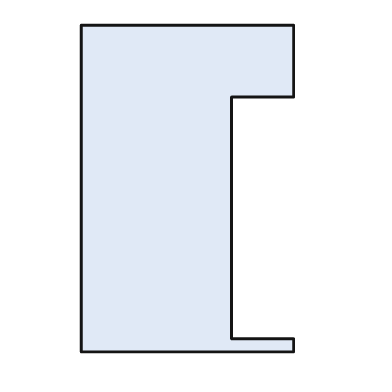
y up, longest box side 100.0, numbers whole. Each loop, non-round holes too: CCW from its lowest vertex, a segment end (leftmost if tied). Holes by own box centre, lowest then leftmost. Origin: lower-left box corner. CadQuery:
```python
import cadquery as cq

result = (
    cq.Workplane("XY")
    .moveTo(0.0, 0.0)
    .lineTo(65.0, 0.0)
    .lineTo(65.0, 4.0)
    .lineTo(46.0, 4.0)
    .lineTo(46.0, 78.0)
    .lineTo(65.0, 78.0)
    .lineTo(65.0, 100.0)
    .lineTo(0.0, 100.0)
    .close()
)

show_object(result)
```